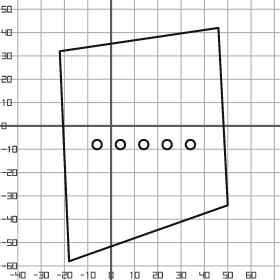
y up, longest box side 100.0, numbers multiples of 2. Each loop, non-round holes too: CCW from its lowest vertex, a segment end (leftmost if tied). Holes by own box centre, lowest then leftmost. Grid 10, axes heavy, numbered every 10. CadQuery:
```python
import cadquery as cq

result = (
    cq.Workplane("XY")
    .moveTo(-18.0, -58.0)
    .lineTo(50.0, -34.0)
    .lineTo(46.0, 42.0)
    .lineTo(-22.0, 32.0)
    .close()
    .moveTo(-6.0, -8.0)
    .circle(2.0)
    .moveTo(4.0, -8.0)
    .circle(2.0)
    .moveTo(14.0, -8.0)
    .circle(2.0)
    .moveTo(24.0, -8.0)
    .circle(2.0)
    .moveTo(34.0, -8.0)
    .circle(2.0)
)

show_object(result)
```